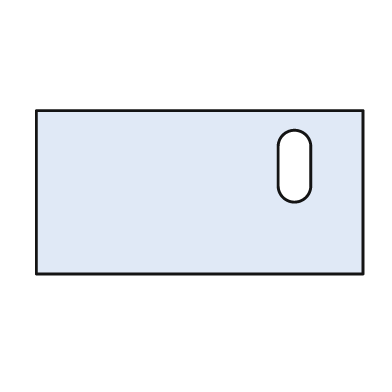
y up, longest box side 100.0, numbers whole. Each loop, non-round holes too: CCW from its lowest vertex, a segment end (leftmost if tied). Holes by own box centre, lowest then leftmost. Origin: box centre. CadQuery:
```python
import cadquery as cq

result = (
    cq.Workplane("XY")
    .moveTo(-50.0, -25.0)
    .lineTo(50.0, -25.0)
    .lineTo(50.0, 25.0)
    .lineTo(-50.0, 25.0)
    .close()
    .moveTo(24.0, 2.0)
    .threePointArc((29.0, -3.0), (34.0, 2.0))
    .lineTo(34.0, 14.0)
    .threePointArc((29.0, 19.0), (24.0, 14.0))
    .close()
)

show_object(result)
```